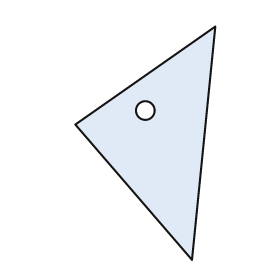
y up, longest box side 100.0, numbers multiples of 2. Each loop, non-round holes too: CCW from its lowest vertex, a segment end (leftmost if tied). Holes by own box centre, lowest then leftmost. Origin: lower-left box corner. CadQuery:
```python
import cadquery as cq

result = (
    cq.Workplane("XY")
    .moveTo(50.0, 0.0)
    .lineTo(60.0, 100.0)
    .lineTo(0.0, 58.0)
    .close()
    .moveTo(30.0, 64.0)
    .circle(4.0)
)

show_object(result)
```